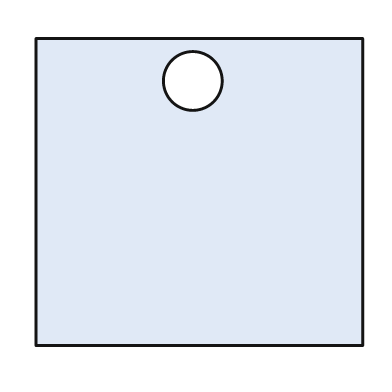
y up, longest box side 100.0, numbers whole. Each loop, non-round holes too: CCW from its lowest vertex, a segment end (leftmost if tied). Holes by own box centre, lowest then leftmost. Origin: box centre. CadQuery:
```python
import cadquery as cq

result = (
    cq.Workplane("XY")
    .moveTo(-50.0, -47.0)
    .lineTo(50.0, -47.0)
    .lineTo(50.0, 47.0)
    .lineTo(-50.0, 47.0)
    .close()
    .moveTo(-2.0, 34.0)
    .circle(9.0)
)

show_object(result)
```